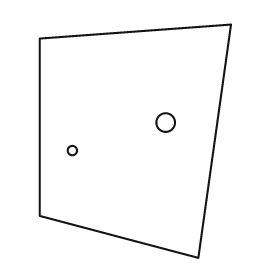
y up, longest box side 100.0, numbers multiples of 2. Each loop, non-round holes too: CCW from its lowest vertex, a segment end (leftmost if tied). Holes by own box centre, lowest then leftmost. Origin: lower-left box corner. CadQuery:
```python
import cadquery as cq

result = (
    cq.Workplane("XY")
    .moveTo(68.0, 0.0)
    .lineTo(82.0, 100.0)
    .lineTo(0.0, 94.0)
    .lineTo(0.0, 18.0)
    .close()
    .moveTo(14.0, 46.0)
    .circle(2.0)
    .moveTo(54.0, 58.0)
    .circle(4.0)
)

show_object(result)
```